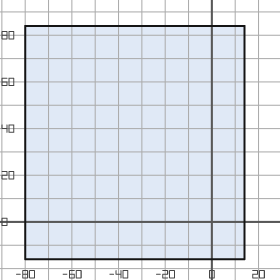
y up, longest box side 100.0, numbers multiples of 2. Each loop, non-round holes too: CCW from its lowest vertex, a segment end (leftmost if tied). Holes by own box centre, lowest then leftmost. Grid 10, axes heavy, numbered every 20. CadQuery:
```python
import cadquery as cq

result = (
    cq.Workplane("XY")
    .moveTo(-80.0, -16.0)
    .lineTo(14.0, -16.0)
    .lineTo(14.0, 84.0)
    .lineTo(-80.0, 84.0)
    .close()
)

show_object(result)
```